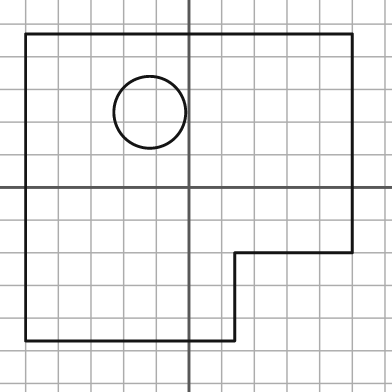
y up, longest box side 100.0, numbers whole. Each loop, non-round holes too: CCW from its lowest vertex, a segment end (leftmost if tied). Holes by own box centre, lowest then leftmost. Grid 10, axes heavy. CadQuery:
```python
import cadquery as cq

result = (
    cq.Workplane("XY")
    .moveTo(-50.0, -47.0)
    .lineTo(14.0, -47.0)
    .lineTo(14.0, -20.0)
    .lineTo(50.0, -20.0)
    .lineTo(50.0, 47.0)
    .lineTo(-50.0, 47.0)
    .close()
    .moveTo(-12.0, 23.0)
    .circle(11.0)
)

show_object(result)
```